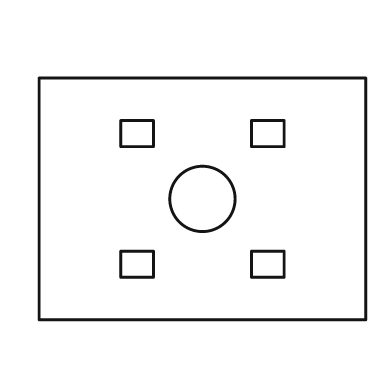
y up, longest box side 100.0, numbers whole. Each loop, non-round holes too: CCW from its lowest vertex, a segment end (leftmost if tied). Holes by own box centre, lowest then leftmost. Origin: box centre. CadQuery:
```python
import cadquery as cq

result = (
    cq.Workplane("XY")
    .moveTo(-50.0, -37.0)
    .lineTo(50.0, -37.0)
    .lineTo(50.0, 37.0)
    .lineTo(-50.0, 37.0)
    .close()
    .moveTo(-25.0, -24.0)
    .lineTo(-15.0, -24.0)
    .lineTo(-15.0, -16.0)
    .lineTo(-25.0, -16.0)
    .close()
    .moveTo(15.0, -24.0)
    .lineTo(25.0, -24.0)
    .lineTo(25.0, -16.0)
    .lineTo(15.0, -16.0)
    .close()
    .moveTo(0.0, 0.0)
    .circle(10.0)
    .moveTo(-25.0, 16.0)
    .lineTo(-15.0, 16.0)
    .lineTo(-15.0, 24.0)
    .lineTo(-25.0, 24.0)
    .close()
    .moveTo(15.0, 16.0)
    .lineTo(25.0, 16.0)
    .lineTo(25.0, 24.0)
    .lineTo(15.0, 24.0)
    .close()
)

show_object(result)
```